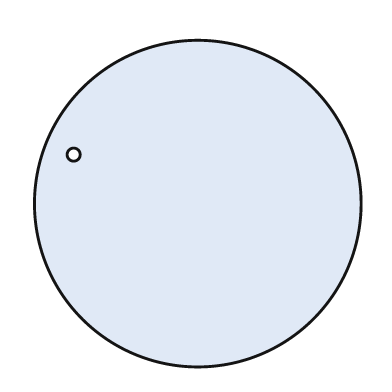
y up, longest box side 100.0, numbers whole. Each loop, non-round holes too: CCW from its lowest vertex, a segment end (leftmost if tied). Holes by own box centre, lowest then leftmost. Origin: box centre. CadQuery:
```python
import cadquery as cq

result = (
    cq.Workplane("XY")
    .moveTo(0.0, 0.0)
    .circle(50.0)
    .moveTo(-38.0, 15.0)
    .circle(2.0)
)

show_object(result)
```